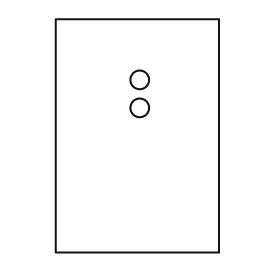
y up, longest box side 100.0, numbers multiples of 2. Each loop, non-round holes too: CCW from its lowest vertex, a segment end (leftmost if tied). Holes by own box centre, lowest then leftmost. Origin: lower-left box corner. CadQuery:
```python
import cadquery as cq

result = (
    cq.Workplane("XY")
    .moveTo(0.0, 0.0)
    .lineTo(70.0, 0.0)
    .lineTo(70.0, 100.0)
    .lineTo(0.0, 100.0)
    .close()
    .moveTo(36.0, 62.0)
    .circle(4.0)
    .moveTo(36.0, 74.0)
    .circle(4.0)
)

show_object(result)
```